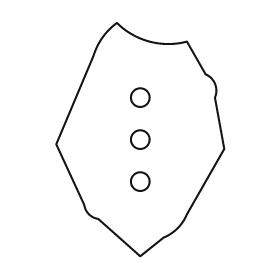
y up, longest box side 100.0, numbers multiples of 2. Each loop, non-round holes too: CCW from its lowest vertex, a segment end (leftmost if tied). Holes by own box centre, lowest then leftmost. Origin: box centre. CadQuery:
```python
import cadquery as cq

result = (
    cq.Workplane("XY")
    .moveTo(0.0, -50.0)
    .lineTo(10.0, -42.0)
    .threePointArc((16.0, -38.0), (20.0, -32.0))
    .lineTo(36.0, -4.0)
    .lineTo(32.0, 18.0)
    .threePointArc((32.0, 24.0), (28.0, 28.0))
    .lineTo(20.0, 42.0)
    .threePointArc((4.0, 42.0), (-10.0, 50.0))
    .threePointArc((-16.0, 44.0), (-20.0, 36.0))
    .lineTo(-36.0, -2.0)
    .lineTo(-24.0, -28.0)
    .threePointArc((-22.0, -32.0), (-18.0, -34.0))
    .close()
    .moveTo(0.0, -18.0)
    .circle(4.0)
    .moveTo(0.0, 0.0)
    .circle(4.0)
    .moveTo(0.0, 18.0)
    .circle(4.0)
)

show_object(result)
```